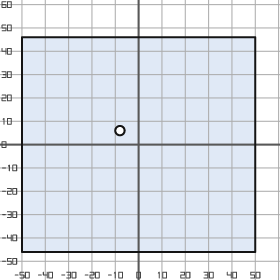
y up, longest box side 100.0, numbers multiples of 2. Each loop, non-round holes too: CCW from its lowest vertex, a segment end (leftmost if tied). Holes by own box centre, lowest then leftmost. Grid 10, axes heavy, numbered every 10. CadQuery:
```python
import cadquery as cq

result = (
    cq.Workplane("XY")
    .moveTo(-50.0, -46.0)
    .lineTo(50.0, -46.0)
    .lineTo(50.0, 46.0)
    .lineTo(-50.0, 46.0)
    .close()
    .moveTo(-8.0, 6.0)
    .circle(2.0)
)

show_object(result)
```